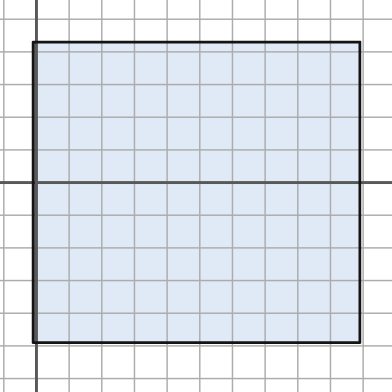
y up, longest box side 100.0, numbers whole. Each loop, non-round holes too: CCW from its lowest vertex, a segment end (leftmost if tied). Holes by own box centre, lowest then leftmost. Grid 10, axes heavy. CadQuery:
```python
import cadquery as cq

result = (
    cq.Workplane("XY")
    .moveTo(-1.0, -49.0)
    .lineTo(99.0, -49.0)
    .lineTo(99.0, 43.0)
    .lineTo(-1.0, 43.0)
    .close()
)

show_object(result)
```